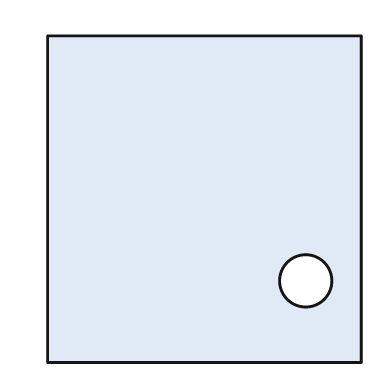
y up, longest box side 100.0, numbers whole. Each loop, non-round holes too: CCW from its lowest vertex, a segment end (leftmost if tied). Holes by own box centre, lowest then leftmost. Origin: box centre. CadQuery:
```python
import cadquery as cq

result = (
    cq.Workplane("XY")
    .moveTo(-48.0, -50.0)
    .lineTo(48.0, -50.0)
    .lineTo(48.0, 50.0)
    .lineTo(-48.0, 50.0)
    .close()
    .moveTo(31.0, -25.0)
    .circle(8.0)
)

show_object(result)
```